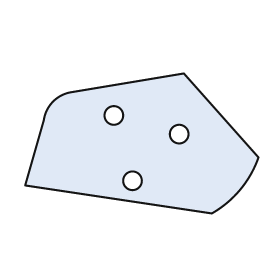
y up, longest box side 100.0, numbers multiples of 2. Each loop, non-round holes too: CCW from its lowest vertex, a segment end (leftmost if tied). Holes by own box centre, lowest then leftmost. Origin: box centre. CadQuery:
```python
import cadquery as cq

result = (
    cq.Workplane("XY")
    .moveTo(30.0, -30.0)
    .threePointArc((42.0, -20.0), (50.0, -6.0))
    .lineTo(18.0, 30.0)
    .lineTo(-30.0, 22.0)
    .threePointArc((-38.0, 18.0), (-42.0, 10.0))
    .lineTo(-50.0, -18.0)
    .close()
    .moveTo(-4.0, -16.0)
    .circle(4.0)
    .moveTo(16.0, 4.0)
    .circle(4.0)
    .moveTo(-12.0, 12.0)
    .circle(4.0)
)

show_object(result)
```